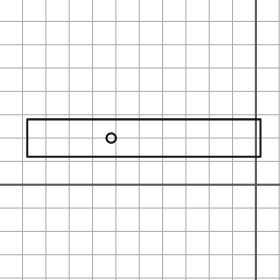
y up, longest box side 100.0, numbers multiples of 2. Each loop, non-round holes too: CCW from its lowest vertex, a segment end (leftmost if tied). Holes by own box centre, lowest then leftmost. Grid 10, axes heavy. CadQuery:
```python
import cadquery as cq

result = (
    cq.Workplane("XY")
    .moveTo(-98.0, 12.0)
    .lineTo(2.0, 12.0)
    .lineTo(2.0, 28.0)
    .lineTo(-98.0, 28.0)
    .close()
    .moveTo(-62.0, 20.0)
    .circle(2.0)
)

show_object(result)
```